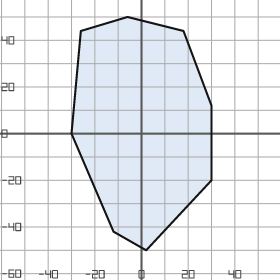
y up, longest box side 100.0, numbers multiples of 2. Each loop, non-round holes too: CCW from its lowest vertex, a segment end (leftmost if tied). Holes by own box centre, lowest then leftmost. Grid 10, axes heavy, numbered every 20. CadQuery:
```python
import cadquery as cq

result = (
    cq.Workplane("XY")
    .moveTo(2.0, -50.0)
    .lineTo(30.0, -20.0)
    .lineTo(30.0, 12.0)
    .lineTo(18.0, 44.0)
    .lineTo(-6.0, 50.0)
    .lineTo(-26.0, 44.0)
    .lineTo(-30.0, 0.0)
    .lineTo(-12.0, -42.0)
    .close()
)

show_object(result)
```